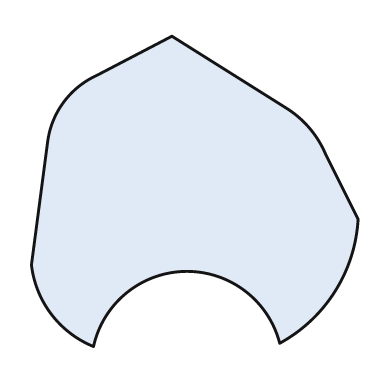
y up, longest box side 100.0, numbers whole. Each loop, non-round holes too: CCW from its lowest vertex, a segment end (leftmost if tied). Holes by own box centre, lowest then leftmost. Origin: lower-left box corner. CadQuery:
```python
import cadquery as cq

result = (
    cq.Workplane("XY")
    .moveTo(19.0, 0.0)
    .threePointArc((47.0, 23.0), (76.0, 1.0))
    .threePointArc((93.0, 17.0), (100.0, 39.0))
    .lineTo(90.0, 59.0)
    .threePointArc((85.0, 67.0), (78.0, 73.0))
    .lineTo(43.0, 95.0)
    .lineTo(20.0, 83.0)
    .threePointArc((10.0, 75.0), (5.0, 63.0))
    .lineTo(0.0, 25.0)
    .threePointArc((6.0, 10.0), (19.0, 0.0))
    .close()
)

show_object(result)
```